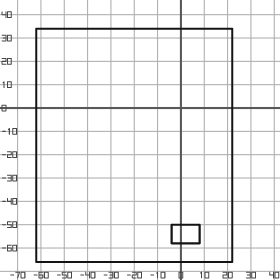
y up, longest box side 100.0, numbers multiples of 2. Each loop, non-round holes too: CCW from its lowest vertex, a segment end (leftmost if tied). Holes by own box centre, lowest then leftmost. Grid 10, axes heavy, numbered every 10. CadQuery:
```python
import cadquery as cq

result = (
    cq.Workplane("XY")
    .moveTo(-62.0, -66.0)
    .lineTo(22.0, -66.0)
    .lineTo(22.0, 34.0)
    .lineTo(-62.0, 34.0)
    .close()
    .moveTo(-4.0, -58.0)
    .lineTo(8.0, -58.0)
    .lineTo(8.0, -50.0)
    .lineTo(-4.0, -50.0)
    .close()
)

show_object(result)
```